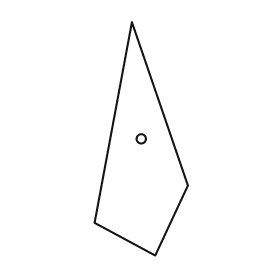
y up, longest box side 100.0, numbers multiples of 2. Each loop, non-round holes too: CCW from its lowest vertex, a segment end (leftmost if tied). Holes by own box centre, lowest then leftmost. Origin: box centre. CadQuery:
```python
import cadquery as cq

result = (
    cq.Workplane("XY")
    .moveTo(6.0, -50.0)
    .lineTo(20.0, -20.0)
    .lineTo(-4.0, 50.0)
    .lineTo(-20.0, -36.0)
    .close()
    .moveTo(0.0, 0.0)
    .circle(2.0)
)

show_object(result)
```